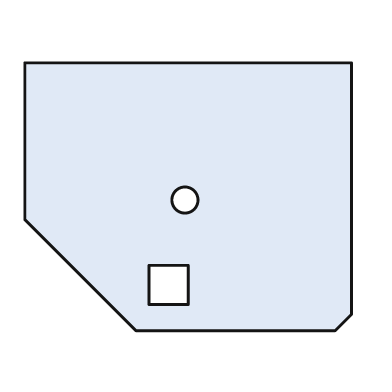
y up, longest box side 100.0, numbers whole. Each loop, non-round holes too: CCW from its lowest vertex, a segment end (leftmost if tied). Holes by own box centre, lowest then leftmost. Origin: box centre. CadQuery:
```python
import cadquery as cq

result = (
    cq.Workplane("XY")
    .moveTo(-16.0, -41.0)
    .lineTo(45.0, -41.0)
    .lineTo(50.0, -36.0)
    .lineTo(50.0, 41.0)
    .lineTo(-50.0, 41.0)
    .lineTo(-50.0, -7.0)
    .close()
    .moveTo(-12.0, -33.0)
    .lineTo(0.0, -33.0)
    .lineTo(0.0, -21.0)
    .lineTo(-12.0, -21.0)
    .close()
    .moveTo(-1.0, -1.0)
    .circle(4.0)
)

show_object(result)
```